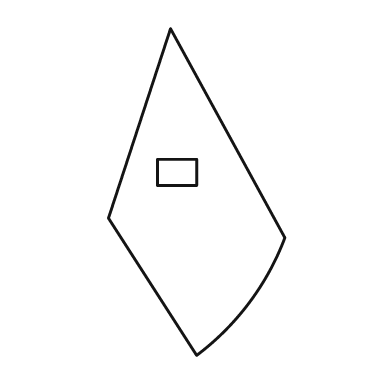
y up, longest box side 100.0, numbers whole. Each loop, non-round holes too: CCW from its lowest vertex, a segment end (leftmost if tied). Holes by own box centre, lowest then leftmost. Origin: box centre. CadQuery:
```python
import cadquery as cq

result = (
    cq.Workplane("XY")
    .moveTo(0.0, -50.0)
    .threePointArc((16.0, -34.0), (27.0, -14.0))
    .lineTo(-8.0, 50.0)
    .lineTo(-27.0, -8.0)
    .close()
    .moveTo(-12.0, 2.0)
    .lineTo(0.0, 2.0)
    .lineTo(0.0, 10.0)
    .lineTo(-12.0, 10.0)
    .close()
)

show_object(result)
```